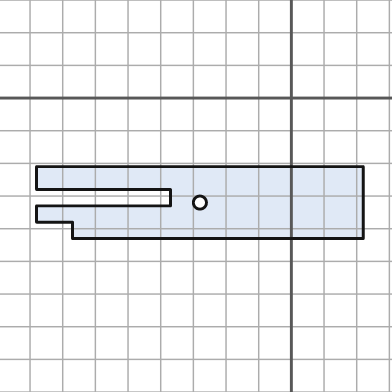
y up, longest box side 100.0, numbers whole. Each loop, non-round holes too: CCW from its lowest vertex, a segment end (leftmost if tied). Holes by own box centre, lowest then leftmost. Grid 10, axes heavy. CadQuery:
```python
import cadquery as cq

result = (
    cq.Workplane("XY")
    .moveTo(-67.0, -43.0)
    .lineTo(22.0, -43.0)
    .lineTo(22.0, -21.0)
    .lineTo(-78.0, -21.0)
    .lineTo(-78.0, -28.0)
    .lineTo(-37.0, -28.0)
    .lineTo(-37.0, -33.0)
    .lineTo(-78.0, -33.0)
    .lineTo(-78.0, -38.0)
    .lineTo(-67.0, -38.0)
    .close()
    .moveTo(-28.0, -32.0)
    .circle(2.0)
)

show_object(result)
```